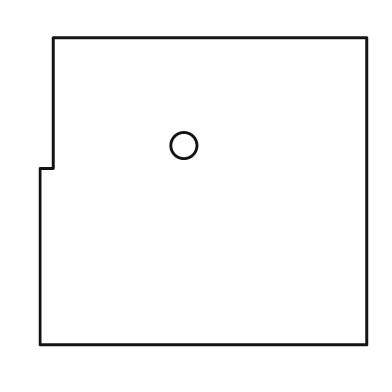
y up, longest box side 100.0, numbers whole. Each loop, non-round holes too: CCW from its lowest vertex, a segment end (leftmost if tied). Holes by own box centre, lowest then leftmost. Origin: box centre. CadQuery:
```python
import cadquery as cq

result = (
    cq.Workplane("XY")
    .moveTo(-50.0, -47.0)
    .lineTo(50.0, -47.0)
    .lineTo(50.0, 47.0)
    .lineTo(-46.0, 47.0)
    .lineTo(-46.0, 7.0)
    .lineTo(-50.0, 7.0)
    .close()
    .moveTo(-6.0, 14.0)
    .circle(4.0)
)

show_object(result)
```